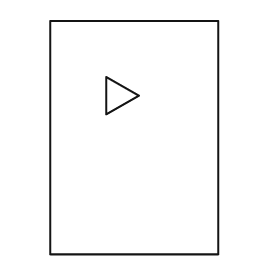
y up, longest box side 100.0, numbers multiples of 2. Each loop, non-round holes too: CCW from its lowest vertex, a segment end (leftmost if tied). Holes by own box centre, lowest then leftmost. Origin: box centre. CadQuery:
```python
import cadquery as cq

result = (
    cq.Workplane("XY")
    .moveTo(-36.0, -50.0)
    .lineTo(36.0, -50.0)
    .lineTo(36.0, 50.0)
    .lineTo(-36.0, 50.0)
    .close()
    .moveTo(-12.0, 10.0)
    .lineTo(2.0, 18.0)
    .lineTo(-12.0, 26.0)
    .close()
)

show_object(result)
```